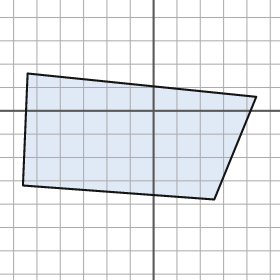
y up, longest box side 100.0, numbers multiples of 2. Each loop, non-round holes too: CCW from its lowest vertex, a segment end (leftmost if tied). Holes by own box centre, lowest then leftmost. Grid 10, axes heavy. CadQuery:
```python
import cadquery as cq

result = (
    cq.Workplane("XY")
    .moveTo(26.0, -38.0)
    .lineTo(44.0, 6.0)
    .lineTo(-54.0, 16.0)
    .lineTo(-56.0, -32.0)
    .close()
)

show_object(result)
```